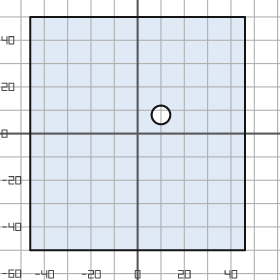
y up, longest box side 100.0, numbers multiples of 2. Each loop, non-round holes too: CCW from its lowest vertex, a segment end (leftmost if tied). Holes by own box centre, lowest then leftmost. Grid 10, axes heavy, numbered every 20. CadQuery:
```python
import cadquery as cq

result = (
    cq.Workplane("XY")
    .moveTo(-46.0, -50.0)
    .lineTo(46.0, -50.0)
    .lineTo(46.0, 50.0)
    .lineTo(-46.0, 50.0)
    .close()
    .moveTo(10.0, 8.0)
    .circle(4.0)
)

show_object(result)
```